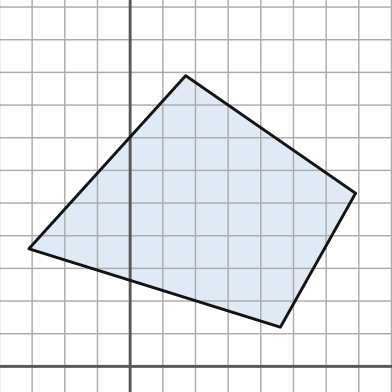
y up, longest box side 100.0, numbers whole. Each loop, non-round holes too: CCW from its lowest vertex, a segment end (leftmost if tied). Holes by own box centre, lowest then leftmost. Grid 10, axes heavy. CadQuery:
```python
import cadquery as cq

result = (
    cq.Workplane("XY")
    .moveTo(46.0, 12.0)
    .lineTo(69.0, 53.0)
    .lineTo(17.0, 89.0)
    .lineTo(-31.0, 36.0)
    .close()
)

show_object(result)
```